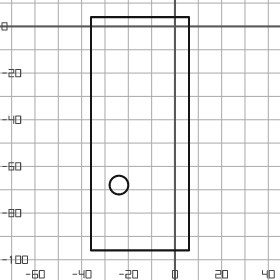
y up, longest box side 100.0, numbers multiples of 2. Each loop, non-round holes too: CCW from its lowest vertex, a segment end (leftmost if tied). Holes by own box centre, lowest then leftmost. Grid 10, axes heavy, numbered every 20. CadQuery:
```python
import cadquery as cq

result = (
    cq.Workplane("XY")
    .moveTo(-36.0, -96.0)
    .lineTo(6.0, -96.0)
    .lineTo(6.0, 4.0)
    .lineTo(-36.0, 4.0)
    .close()
    .moveTo(-24.0, -68.0)
    .circle(4.0)
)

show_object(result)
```